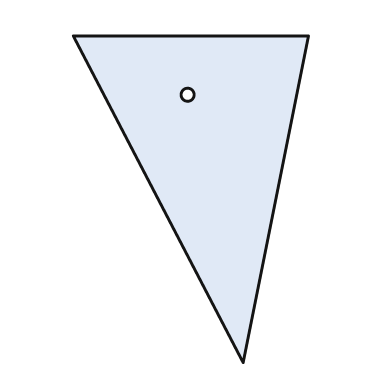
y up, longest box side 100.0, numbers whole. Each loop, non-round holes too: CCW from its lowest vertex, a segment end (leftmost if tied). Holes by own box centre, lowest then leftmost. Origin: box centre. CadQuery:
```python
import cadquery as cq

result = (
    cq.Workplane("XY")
    .moveTo(16.0, -50.0)
    .lineTo(36.0, 50.0)
    .lineTo(-36.0, 50.0)
    .close()
    .moveTo(-1.0, 32.0)
    .circle(2.0)
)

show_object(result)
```